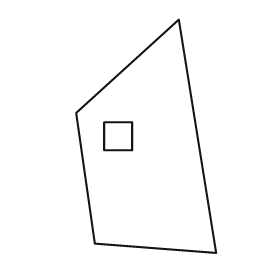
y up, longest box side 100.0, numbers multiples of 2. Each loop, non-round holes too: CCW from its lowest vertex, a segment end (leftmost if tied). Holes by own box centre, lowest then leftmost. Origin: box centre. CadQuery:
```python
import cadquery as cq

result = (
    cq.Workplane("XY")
    .moveTo(30.0, -50.0)
    .lineTo(14.0, 50.0)
    .lineTo(-30.0, 10.0)
    .lineTo(-22.0, -46.0)
    .close()
    .moveTo(-18.0, -6.0)
    .lineTo(-6.0, -6.0)
    .lineTo(-6.0, 6.0)
    .lineTo(-18.0, 6.0)
    .close()
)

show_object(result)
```